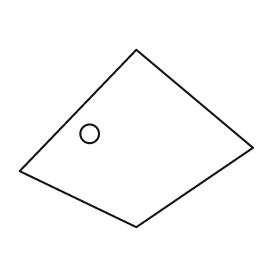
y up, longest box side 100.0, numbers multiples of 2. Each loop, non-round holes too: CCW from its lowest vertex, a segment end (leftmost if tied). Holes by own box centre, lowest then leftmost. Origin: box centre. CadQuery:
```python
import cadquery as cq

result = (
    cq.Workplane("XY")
    .moveTo(0.0, -38.0)
    .lineTo(50.0, -4.0)
    .lineTo(0.0, 38.0)
    .lineTo(-50.0, -14.0)
    .close()
    .moveTo(-20.0, 2.0)
    .circle(4.0)
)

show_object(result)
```